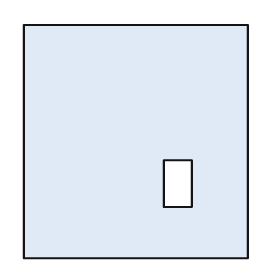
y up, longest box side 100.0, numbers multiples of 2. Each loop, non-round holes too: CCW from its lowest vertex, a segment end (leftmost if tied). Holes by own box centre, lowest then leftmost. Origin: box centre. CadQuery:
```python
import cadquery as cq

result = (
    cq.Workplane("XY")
    .moveTo(-48.0, -50.0)
    .lineTo(48.0, -50.0)
    .lineTo(48.0, 50.0)
    .lineTo(-48.0, 50.0)
    .close()
    .moveTo(12.0, -28.0)
    .lineTo(24.0, -28.0)
    .lineTo(24.0, -8.0)
    .lineTo(12.0, -8.0)
    .close()
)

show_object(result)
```